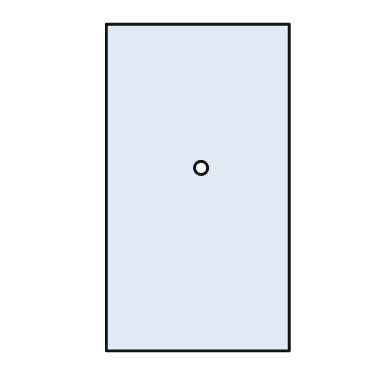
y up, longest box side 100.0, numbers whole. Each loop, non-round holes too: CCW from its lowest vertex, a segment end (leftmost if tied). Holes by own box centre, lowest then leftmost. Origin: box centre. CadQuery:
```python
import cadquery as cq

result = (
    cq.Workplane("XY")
    .moveTo(-28.0, -50.0)
    .lineTo(28.0, -50.0)
    .lineTo(28.0, 50.0)
    .lineTo(-28.0, 50.0)
    .close()
    .moveTo(1.0, 6.0)
    .circle(2.0)
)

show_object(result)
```